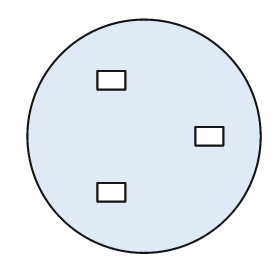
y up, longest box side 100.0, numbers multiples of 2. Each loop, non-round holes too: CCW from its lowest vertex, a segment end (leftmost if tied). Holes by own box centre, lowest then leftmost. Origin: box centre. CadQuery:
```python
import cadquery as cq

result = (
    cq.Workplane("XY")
    .moveTo(0.0, 0.0)
    .circle(50.0)
    .moveTo(-20.0, -28.0)
    .lineTo(-8.0, -28.0)
    .lineTo(-8.0, -20.0)
    .lineTo(-20.0, -20.0)
    .close()
    .moveTo(22.0, -4.0)
    .lineTo(34.0, -4.0)
    .lineTo(34.0, 4.0)
    .lineTo(22.0, 4.0)
    .close()
    .moveTo(-20.0, 20.0)
    .lineTo(-8.0, 20.0)
    .lineTo(-8.0, 28.0)
    .lineTo(-20.0, 28.0)
    .close()
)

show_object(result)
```